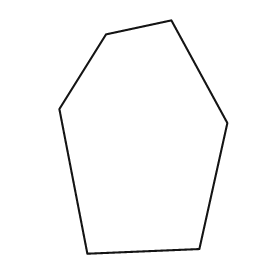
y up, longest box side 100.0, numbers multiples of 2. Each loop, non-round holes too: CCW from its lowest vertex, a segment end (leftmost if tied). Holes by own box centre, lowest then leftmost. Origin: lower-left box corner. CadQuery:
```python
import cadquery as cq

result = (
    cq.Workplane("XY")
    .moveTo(12.0, 0.0)
    .lineTo(60.0, 2.0)
    .lineTo(72.0, 56.0)
    .lineTo(48.0, 100.0)
    .lineTo(20.0, 94.0)
    .lineTo(0.0, 62.0)
    .close()
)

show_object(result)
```